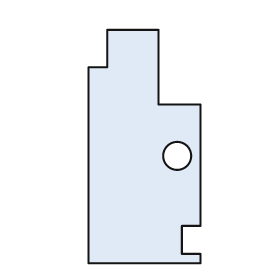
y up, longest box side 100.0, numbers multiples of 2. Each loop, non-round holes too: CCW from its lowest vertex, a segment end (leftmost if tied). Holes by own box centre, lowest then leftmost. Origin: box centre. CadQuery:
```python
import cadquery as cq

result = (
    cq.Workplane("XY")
    .moveTo(-24.0, -50.0)
    .lineTo(24.0, -50.0)
    .lineTo(24.0, -46.0)
    .lineTo(16.0, -46.0)
    .lineTo(16.0, -34.0)
    .lineTo(24.0, -34.0)
    .lineTo(24.0, 18.0)
    .lineTo(6.0, 18.0)
    .lineTo(6.0, 50.0)
    .lineTo(-16.0, 50.0)
    .lineTo(-16.0, 34.0)
    .lineTo(-24.0, 34.0)
    .close()
    .moveTo(14.0, -4.0)
    .circle(6.0)
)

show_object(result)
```